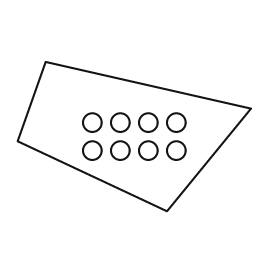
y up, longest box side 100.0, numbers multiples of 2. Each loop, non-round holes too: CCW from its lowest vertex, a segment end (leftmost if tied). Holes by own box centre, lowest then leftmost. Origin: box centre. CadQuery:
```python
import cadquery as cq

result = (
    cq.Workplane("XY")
    .moveTo(14.0, -32.0)
    .lineTo(50.0, 12.0)
    .lineTo(-38.0, 32.0)
    .lineTo(-50.0, -2.0)
    .close()
    .moveTo(-18.0, -6.0)
    .circle(4.0)
    .moveTo(-6.0, -6.0)
    .circle(4.0)
    .moveTo(6.0, -6.0)
    .circle(4.0)
    .moveTo(18.0, -6.0)
    .circle(4.0)
    .moveTo(-18.0, 6.0)
    .circle(4.0)
    .moveTo(-6.0, 6.0)
    .circle(4.0)
    .moveTo(6.0, 6.0)
    .circle(4.0)
    .moveTo(18.0, 6.0)
    .circle(4.0)
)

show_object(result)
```